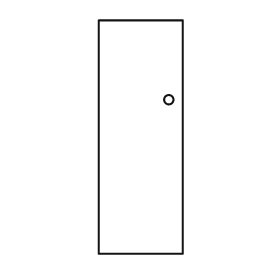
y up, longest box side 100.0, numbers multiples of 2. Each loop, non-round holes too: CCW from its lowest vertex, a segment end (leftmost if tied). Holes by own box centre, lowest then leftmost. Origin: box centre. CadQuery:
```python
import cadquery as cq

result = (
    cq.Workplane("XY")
    .moveTo(-18.0, -50.0)
    .lineTo(18.0, -50.0)
    .lineTo(18.0, 50.0)
    .lineTo(-18.0, 50.0)
    .close()
    .moveTo(12.0, 16.0)
    .circle(2.0)
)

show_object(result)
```